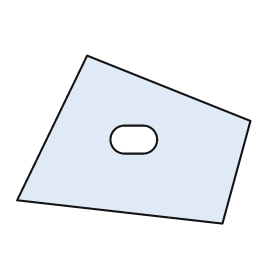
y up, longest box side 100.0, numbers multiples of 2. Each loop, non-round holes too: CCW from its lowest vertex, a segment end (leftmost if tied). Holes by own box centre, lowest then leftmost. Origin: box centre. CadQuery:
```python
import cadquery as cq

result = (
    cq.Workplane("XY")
    .moveTo(38.0, -36.0)
    .lineTo(50.0, 8.0)
    .lineTo(-20.0, 36.0)
    .lineTo(-50.0, -26.0)
    .close()
    .moveTo(-4.0, -6.0)
    .lineTo(4.0, -6.0)
    .threePointArc((10.0, 0.0), (4.0, 6.0))
    .lineTo(-4.0, 6.0)
    .threePointArc((-10.0, 0.0), (-4.0, -6.0))
    .close()
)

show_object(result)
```